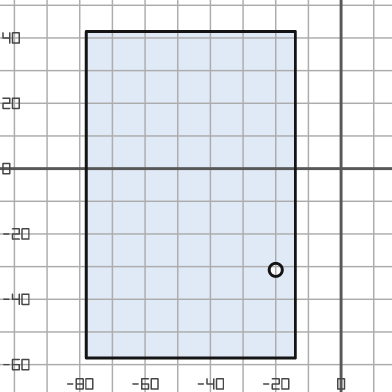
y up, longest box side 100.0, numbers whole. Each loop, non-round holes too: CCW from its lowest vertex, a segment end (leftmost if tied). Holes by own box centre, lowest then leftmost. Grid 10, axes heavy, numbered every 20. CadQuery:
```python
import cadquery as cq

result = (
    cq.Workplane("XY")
    .moveTo(-78.0, -58.0)
    .lineTo(-14.0, -58.0)
    .lineTo(-14.0, 42.0)
    .lineTo(-78.0, 42.0)
    .close()
    .moveTo(-20.0, -31.0)
    .circle(2.0)
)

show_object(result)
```